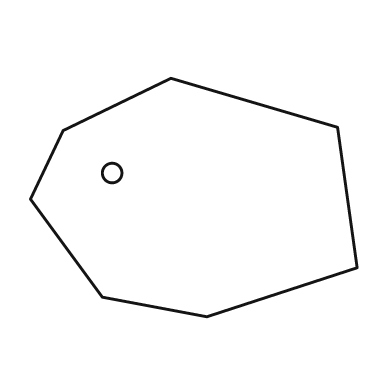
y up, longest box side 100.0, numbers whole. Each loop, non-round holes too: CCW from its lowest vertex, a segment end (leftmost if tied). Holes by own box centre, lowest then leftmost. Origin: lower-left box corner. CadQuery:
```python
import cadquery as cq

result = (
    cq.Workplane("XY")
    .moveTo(54.0, 0.0)
    .lineTo(100.0, 15.0)
    .lineTo(94.0, 58.0)
    .lineTo(43.0, 73.0)
    .lineTo(10.0, 57.0)
    .lineTo(0.0, 36.0)
    .lineTo(22.0, 6.0)
    .close()
    .moveTo(25.0, 44.0)
    .circle(3.0)
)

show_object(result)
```